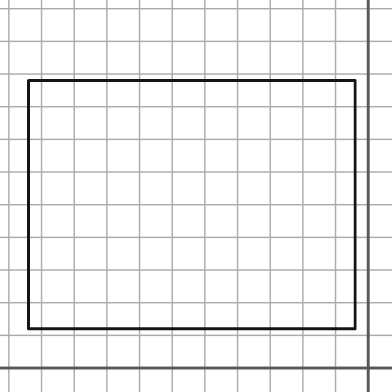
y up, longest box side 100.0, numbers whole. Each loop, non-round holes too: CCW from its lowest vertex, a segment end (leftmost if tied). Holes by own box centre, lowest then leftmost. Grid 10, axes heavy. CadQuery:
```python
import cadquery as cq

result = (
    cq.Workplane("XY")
    .moveTo(-104.0, 12.0)
    .lineTo(-4.0, 12.0)
    .lineTo(-4.0, 88.0)
    .lineTo(-104.0, 88.0)
    .close()
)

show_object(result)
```